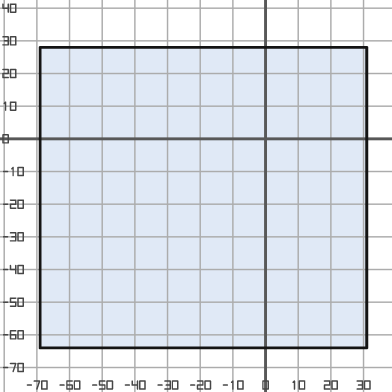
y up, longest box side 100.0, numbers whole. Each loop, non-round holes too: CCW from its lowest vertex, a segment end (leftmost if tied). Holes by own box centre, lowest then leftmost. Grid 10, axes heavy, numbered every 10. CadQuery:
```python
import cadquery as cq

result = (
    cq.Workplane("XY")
    .moveTo(-69.0, -64.0)
    .lineTo(31.0, -64.0)
    .lineTo(31.0, 28.0)
    .lineTo(-69.0, 28.0)
    .close()
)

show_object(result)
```